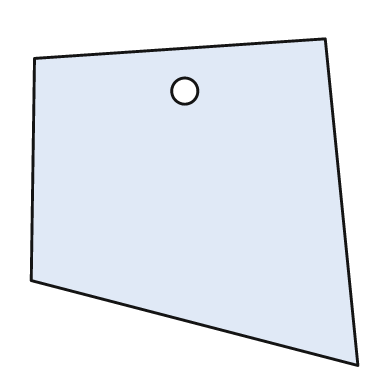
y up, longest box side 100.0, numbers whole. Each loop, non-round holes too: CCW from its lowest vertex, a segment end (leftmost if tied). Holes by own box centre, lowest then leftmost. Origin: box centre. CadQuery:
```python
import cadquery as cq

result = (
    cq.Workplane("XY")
    .moveTo(50.0, -50.0)
    .lineTo(40.0, 50.0)
    .lineTo(-49.0, 44.0)
    .lineTo(-50.0, -24.0)
    .close()
    .moveTo(-3.0, 34.0)
    .circle(4.0)
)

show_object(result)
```